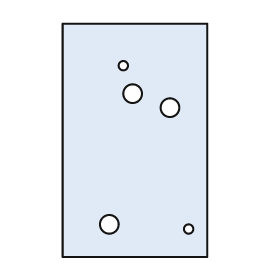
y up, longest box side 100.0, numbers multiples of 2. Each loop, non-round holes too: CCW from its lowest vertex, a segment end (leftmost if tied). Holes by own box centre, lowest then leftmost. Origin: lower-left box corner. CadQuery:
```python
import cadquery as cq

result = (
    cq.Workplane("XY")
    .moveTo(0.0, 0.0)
    .lineTo(62.0, 0.0)
    .lineTo(62.0, 100.0)
    .lineTo(0.0, 100.0)
    .close()
    .moveTo(54.0, 12.0)
    .circle(2.0)
    .moveTo(20.0, 14.0)
    .circle(4.0)
    .moveTo(46.0, 64.0)
    .circle(4.0)
    .moveTo(30.0, 70.0)
    .circle(4.0)
    .moveTo(26.0, 82.0)
    .circle(2.0)
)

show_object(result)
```